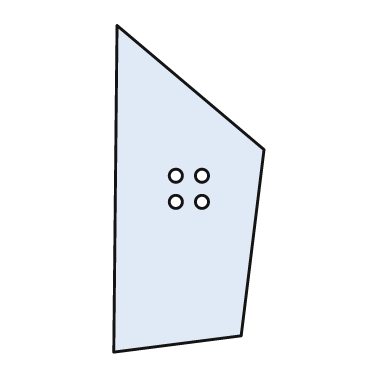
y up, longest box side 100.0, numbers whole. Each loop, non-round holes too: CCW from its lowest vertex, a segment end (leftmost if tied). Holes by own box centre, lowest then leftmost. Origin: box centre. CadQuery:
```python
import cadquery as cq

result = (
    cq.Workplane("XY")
    .moveTo(-23.0, -50.0)
    .lineTo(16.0, -45.0)
    .lineTo(23.0, 12.0)
    .lineTo(-22.0, 50.0)
    .close()
    .moveTo(-4.0, -4.0)
    .circle(2.0)
    .moveTo(4.0, -4.0)
    .circle(2.0)
    .moveTo(-4.0, 4.0)
    .circle(2.0)
    .moveTo(4.0, 4.0)
    .circle(2.0)
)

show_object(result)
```